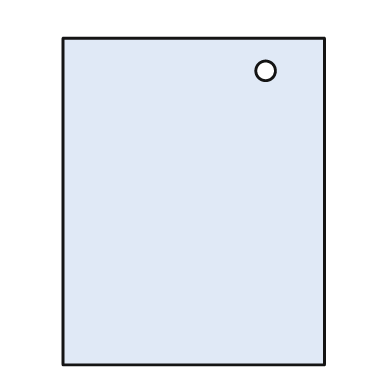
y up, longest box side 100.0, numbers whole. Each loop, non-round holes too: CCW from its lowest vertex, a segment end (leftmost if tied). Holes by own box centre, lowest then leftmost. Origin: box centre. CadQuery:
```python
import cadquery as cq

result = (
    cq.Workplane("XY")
    .moveTo(-40.0, -50.0)
    .lineTo(40.0, -50.0)
    .lineTo(40.0, 50.0)
    .lineTo(-40.0, 50.0)
    .close()
    .moveTo(22.0, 40.0)
    .circle(3.0)
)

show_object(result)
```